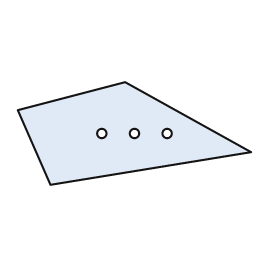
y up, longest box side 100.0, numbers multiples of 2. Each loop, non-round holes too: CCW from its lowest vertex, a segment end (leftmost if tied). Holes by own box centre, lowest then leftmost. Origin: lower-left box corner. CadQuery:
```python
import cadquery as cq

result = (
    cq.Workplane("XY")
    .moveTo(14.0, 0.0)
    .lineTo(100.0, 14.0)
    .lineTo(46.0, 44.0)
    .lineTo(0.0, 32.0)
    .close()
    .moveTo(36.0, 22.0)
    .circle(2.0)
    .moveTo(50.0, 22.0)
    .circle(2.0)
    .moveTo(64.0, 22.0)
    .circle(2.0)
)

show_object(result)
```